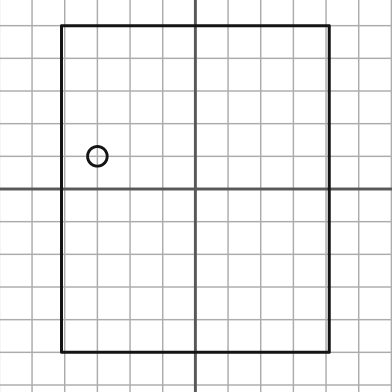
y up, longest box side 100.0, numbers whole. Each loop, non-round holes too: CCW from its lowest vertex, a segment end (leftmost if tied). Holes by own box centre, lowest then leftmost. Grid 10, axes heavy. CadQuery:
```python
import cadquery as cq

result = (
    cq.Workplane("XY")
    .moveTo(-41.0, -50.0)
    .lineTo(41.0, -50.0)
    .lineTo(41.0, 50.0)
    .lineTo(-41.0, 50.0)
    .close()
    .moveTo(-30.0, 10.0)
    .circle(3.0)
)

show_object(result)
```